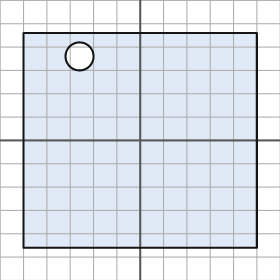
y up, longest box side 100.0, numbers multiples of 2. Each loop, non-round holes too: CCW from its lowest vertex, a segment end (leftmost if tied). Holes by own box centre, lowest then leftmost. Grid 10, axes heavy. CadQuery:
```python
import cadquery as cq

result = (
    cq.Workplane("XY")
    .moveTo(-50.0, -46.0)
    .lineTo(50.0, -46.0)
    .lineTo(50.0, 46.0)
    .lineTo(-50.0, 46.0)
    .close()
    .moveTo(-26.0, 36.0)
    .circle(6.0)
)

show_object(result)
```